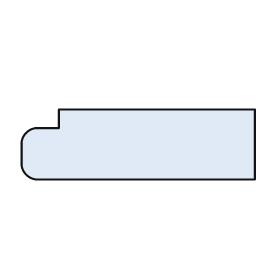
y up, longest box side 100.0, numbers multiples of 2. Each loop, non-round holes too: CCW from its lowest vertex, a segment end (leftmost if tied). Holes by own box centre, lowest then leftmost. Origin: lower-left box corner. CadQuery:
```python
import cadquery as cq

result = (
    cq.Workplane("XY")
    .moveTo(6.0, 0.0)
    .lineTo(100.0, 0.0)
    .lineTo(100.0, 30.0)
    .lineTo(16.0, 30.0)
    .lineTo(16.0, 22.0)
    .lineTo(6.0, 22.0)
    .threePointArc((2.0, 20.0), (0.0, 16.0))
    .lineTo(0.0, 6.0)
    .threePointArc((2.0, 2.0), (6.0, 0.0))
    .close()
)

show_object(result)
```